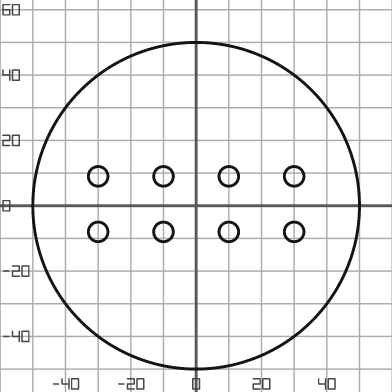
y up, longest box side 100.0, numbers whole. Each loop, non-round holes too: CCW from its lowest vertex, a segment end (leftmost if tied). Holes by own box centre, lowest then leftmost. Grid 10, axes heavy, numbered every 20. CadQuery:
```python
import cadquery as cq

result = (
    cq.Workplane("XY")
    .moveTo(0.0, 0.0)
    .circle(50.0)
    .moveTo(-30.0, -8.0)
    .circle(3.0)
    .moveTo(-10.0, -8.0)
    .circle(3.0)
    .moveTo(10.0, -8.0)
    .circle(3.0)
    .moveTo(30.0, -8.0)
    .circle(3.0)
    .moveTo(-30.0, 9.0)
    .circle(3.0)
    .moveTo(-10.0, 9.0)
    .circle(3.0)
    .moveTo(10.0, 9.0)
    .circle(3.0)
    .moveTo(30.0, 9.0)
    .circle(3.0)
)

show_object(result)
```